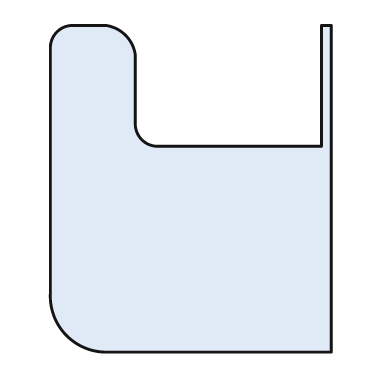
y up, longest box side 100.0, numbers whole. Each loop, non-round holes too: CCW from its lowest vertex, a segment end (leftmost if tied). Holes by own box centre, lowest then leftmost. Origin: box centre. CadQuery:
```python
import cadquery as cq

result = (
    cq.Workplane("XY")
    .moveTo(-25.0, -50.0)
    .lineTo(43.0, -50.0)
    .lineTo(43.0, 50.0)
    .lineTo(40.0, 50.0)
    .lineTo(40.0, 13.0)
    .lineTo(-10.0, 13.0)
    .threePointArc((-15.0, 15.0), (-17.0, 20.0))
    .lineTo(-17.0, 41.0)
    .threePointArc((-20.0, 47.0), (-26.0, 50.0))
    .lineTo(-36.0, 50.0)
    .threePointArc((-41.0, 48.0), (-43.0, 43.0))
    .lineTo(-43.0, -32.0)
    .threePointArc((-38.0, -45.0), (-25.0, -50.0))
    .close()
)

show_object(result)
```